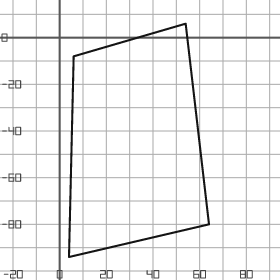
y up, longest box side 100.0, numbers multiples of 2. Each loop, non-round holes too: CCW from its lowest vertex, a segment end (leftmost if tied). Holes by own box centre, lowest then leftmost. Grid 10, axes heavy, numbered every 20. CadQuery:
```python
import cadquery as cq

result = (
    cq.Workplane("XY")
    .moveTo(4.0, -94.0)
    .lineTo(64.0, -80.0)
    .lineTo(54.0, 6.0)
    .lineTo(6.0, -8.0)
    .close()
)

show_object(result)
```